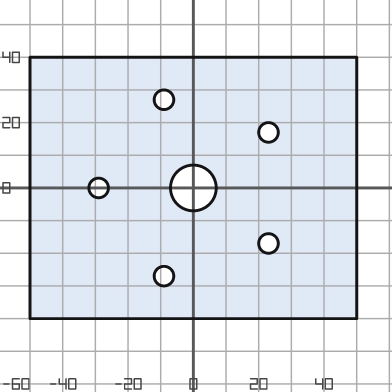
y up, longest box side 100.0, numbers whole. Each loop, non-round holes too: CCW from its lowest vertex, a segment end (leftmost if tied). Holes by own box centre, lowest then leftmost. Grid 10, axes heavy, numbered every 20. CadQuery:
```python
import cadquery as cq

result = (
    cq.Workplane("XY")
    .moveTo(-50.0, -40.0)
    .lineTo(50.0, -40.0)
    .lineTo(50.0, 40.0)
    .lineTo(-50.0, 40.0)
    .close()
    .moveTo(-9.0, -27.0)
    .circle(3.0)
    .moveTo(23.0, -17.0)
    .circle(3.0)
    .moveTo(-29.0, 0.0)
    .circle(3.0)
    .moveTo(0.0, 0.0)
    .circle(7.0)
    .moveTo(23.0, 17.0)
    .circle(3.0)
    .moveTo(-9.0, 27.0)
    .circle(3.0)
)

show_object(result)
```